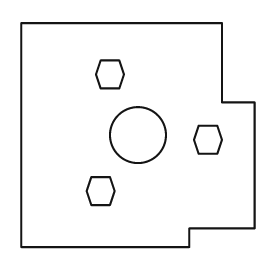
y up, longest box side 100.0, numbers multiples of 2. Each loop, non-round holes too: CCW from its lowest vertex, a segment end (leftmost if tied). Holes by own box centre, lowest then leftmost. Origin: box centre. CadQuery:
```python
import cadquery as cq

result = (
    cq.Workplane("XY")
    .moveTo(-50.0, -48.0)
    .lineTo(22.0, -48.0)
    .lineTo(22.0, -40.0)
    .lineTo(50.0, -40.0)
    .lineTo(50.0, 14.0)
    .lineTo(36.0, 14.0)
    .lineTo(36.0, 48.0)
    .lineTo(-50.0, 48.0)
    .close()
    .moveTo(-20.0, -30.0)
    .lineTo(-12.0, -30.0)
    .lineTo(-10.0, -24.0)
    .lineTo(-12.0, -18.0)
    .lineTo(-20.0, -18.0)
    .lineTo(-22.0, -24.0)
    .close()
    .moveTo(26.0, -8.0)
    .lineTo(34.0, -8.0)
    .lineTo(36.0, -2.0)
    .lineTo(34.0, 4.0)
    .lineTo(26.0, 4.0)
    .lineTo(24.0, -2.0)
    .close()
    .moveTo(0.0, 0.0)
    .circle(12.0)
    .moveTo(-16.0, 20.0)
    .lineTo(-8.0, 20.0)
    .lineTo(-6.0, 26.0)
    .lineTo(-8.0, 32.0)
    .lineTo(-16.0, 32.0)
    .lineTo(-18.0, 26.0)
    .close()
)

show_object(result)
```